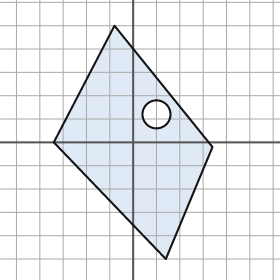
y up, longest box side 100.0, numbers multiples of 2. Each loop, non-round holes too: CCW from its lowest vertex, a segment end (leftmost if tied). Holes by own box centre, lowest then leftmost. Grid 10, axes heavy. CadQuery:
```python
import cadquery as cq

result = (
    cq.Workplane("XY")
    .moveTo(14.0, -50.0)
    .lineTo(34.0, -2.0)
    .lineTo(-8.0, 50.0)
    .lineTo(-34.0, 0.0)
    .close()
    .moveTo(10.0, 12.0)
    .circle(6.0)
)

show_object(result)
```